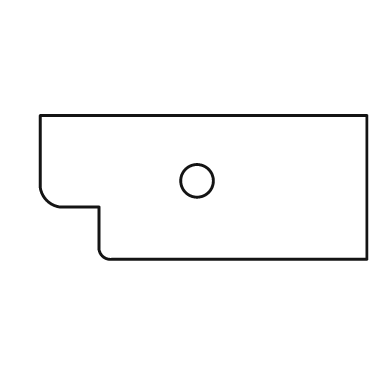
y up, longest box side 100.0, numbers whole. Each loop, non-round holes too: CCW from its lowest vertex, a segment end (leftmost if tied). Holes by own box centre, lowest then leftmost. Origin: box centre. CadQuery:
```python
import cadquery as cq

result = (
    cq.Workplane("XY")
    .moveTo(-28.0, -22.0)
    .lineTo(50.0, -22.0)
    .lineTo(50.0, 22.0)
    .lineTo(-50.0, 22.0)
    .lineTo(-50.0, 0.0)
    .threePointArc((-48.0, -4.0), (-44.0, -6.0))
    .lineTo(-32.0, -6.0)
    .lineTo(-32.0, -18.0)
    .threePointArc((-31.0, -21.0), (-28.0, -22.0))
    .close()
    .moveTo(-2.0, 2.0)
    .circle(5.0)
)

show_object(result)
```